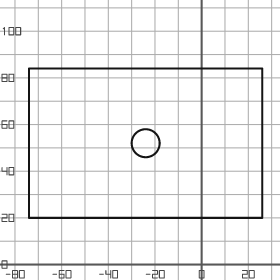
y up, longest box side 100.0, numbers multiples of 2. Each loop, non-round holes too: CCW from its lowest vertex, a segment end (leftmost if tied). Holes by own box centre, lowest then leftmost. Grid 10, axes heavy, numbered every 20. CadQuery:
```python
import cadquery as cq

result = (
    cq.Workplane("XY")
    .moveTo(-74.0, 20.0)
    .lineTo(26.0, 20.0)
    .lineTo(26.0, 84.0)
    .lineTo(-74.0, 84.0)
    .close()
    .moveTo(-24.0, 52.0)
    .circle(6.0)
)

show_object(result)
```